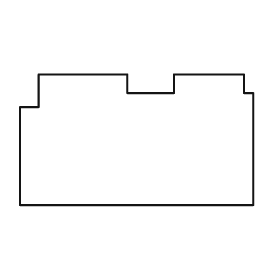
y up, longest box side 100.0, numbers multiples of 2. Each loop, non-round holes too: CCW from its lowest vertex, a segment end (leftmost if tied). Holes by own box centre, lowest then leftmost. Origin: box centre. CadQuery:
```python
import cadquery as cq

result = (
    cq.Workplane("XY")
    .moveTo(-50.0, -28.0)
    .lineTo(50.0, -28.0)
    .lineTo(50.0, 20.0)
    .lineTo(46.0, 20.0)
    .lineTo(46.0, 28.0)
    .lineTo(16.0, 28.0)
    .lineTo(16.0, 20.0)
    .lineTo(-4.0, 20.0)
    .lineTo(-4.0, 28.0)
    .lineTo(-42.0, 28.0)
    .lineTo(-42.0, 14.0)
    .lineTo(-50.0, 14.0)
    .close()
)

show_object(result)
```